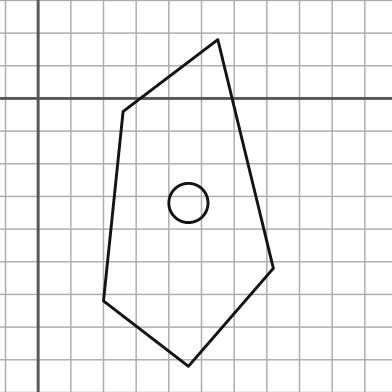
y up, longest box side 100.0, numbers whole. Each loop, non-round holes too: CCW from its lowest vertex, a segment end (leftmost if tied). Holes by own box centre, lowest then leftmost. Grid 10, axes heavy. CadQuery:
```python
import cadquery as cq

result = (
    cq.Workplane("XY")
    .moveTo(46.0, -82.0)
    .lineTo(72.0, -52.0)
    .lineTo(55.0, 18.0)
    .lineTo(26.0, -4.0)
    .lineTo(20.0, -62.0)
    .close()
    .moveTo(46.0, -32.0)
    .circle(6.0)
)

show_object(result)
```